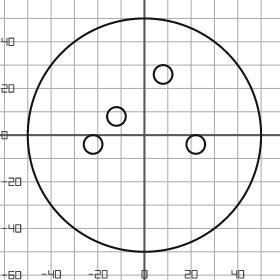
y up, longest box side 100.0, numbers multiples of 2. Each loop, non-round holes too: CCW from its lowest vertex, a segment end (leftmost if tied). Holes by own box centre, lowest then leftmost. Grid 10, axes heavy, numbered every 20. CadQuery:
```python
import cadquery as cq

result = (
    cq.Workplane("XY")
    .moveTo(0.0, 0.0)
    .circle(50.0)
    .moveTo(-22.0, -4.0)
    .circle(4.0)
    .moveTo(22.0, -4.0)
    .circle(4.0)
    .moveTo(-12.0, 8.0)
    .circle(4.0)
    .moveTo(8.0, 26.0)
    .circle(4.0)
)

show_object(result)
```